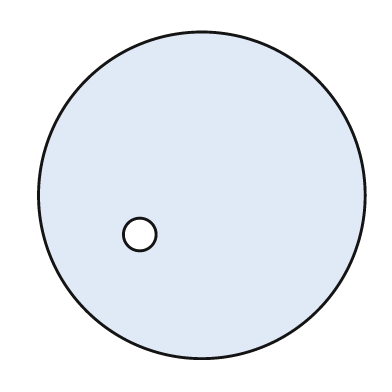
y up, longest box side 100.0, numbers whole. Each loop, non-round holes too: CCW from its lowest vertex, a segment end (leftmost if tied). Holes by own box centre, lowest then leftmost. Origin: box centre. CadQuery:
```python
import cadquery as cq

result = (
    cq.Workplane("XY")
    .moveTo(0.0, 0.0)
    .circle(50.0)
    .moveTo(-19.0, -12.0)
    .circle(5.0)
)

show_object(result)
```